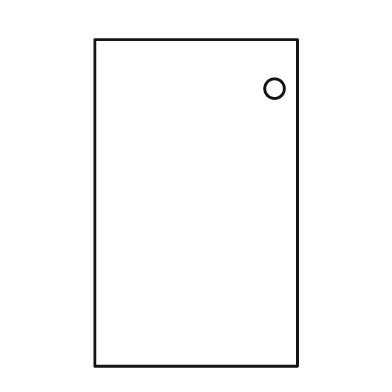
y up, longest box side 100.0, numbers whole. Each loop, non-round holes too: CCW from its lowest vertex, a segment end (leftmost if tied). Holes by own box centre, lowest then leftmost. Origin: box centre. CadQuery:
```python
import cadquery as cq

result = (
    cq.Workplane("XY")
    .moveTo(-31.0, -50.0)
    .lineTo(31.0, -50.0)
    .lineTo(31.0, 50.0)
    .lineTo(-31.0, 50.0)
    .close()
    .moveTo(24.0, 35.0)
    .circle(3.0)
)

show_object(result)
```